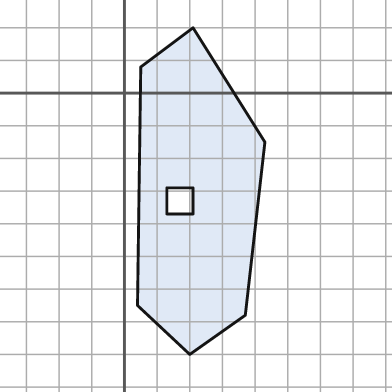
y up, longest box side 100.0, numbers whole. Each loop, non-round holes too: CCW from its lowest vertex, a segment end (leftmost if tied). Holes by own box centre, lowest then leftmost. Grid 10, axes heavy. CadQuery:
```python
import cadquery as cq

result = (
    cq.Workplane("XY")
    .moveTo(20.0, -80.0)
    .lineTo(37.0, -68.0)
    .lineTo(43.0, -15.0)
    .lineTo(21.0, 20.0)
    .lineTo(5.0, 8.0)
    .lineTo(4.0, -65.0)
    .close()
    .moveTo(13.0, -37.0)
    .lineTo(21.0, -37.0)
    .lineTo(21.0, -29.0)
    .lineTo(13.0, -29.0)
    .close()
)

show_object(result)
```